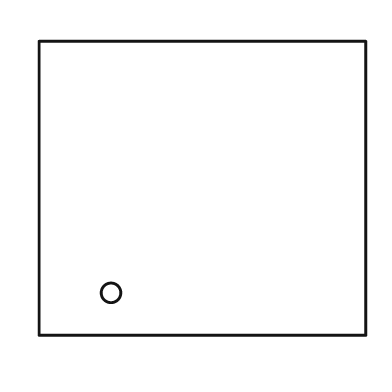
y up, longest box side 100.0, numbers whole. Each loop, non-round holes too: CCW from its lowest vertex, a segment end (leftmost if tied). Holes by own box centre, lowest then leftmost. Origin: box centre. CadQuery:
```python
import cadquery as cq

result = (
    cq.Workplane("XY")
    .moveTo(-50.0, -45.0)
    .lineTo(50.0, -45.0)
    .lineTo(50.0, 45.0)
    .lineTo(-50.0, 45.0)
    .close()
    .moveTo(-28.0, -32.0)
    .circle(3.0)
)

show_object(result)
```